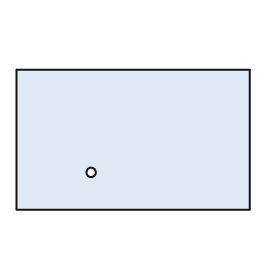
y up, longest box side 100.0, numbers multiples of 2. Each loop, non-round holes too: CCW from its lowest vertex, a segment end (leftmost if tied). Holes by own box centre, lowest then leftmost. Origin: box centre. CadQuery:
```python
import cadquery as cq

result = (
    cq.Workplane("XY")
    .moveTo(-50.0, -30.0)
    .lineTo(50.0, -30.0)
    .lineTo(50.0, 30.0)
    .lineTo(-50.0, 30.0)
    .close()
    .moveTo(-18.0, -14.0)
    .circle(2.0)
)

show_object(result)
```